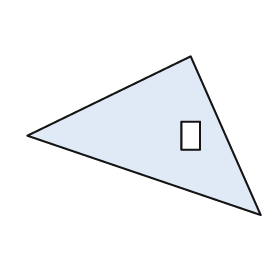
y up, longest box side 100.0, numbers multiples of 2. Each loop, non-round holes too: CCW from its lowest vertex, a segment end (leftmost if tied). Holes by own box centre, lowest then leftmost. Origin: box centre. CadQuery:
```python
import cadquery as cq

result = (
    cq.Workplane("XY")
    .moveTo(50.0, -34.0)
    .lineTo(20.0, 34.0)
    .lineTo(-50.0, 0.0)
    .close()
    .moveTo(16.0, -6.0)
    .lineTo(24.0, -6.0)
    .lineTo(24.0, 6.0)
    .lineTo(16.0, 6.0)
    .close()
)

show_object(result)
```